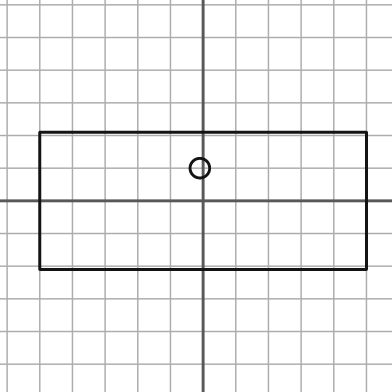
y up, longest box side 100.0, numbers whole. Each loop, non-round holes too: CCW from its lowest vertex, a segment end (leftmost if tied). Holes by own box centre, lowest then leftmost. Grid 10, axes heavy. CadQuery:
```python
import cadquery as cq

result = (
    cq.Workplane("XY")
    .moveTo(-50.0, -21.0)
    .lineTo(50.0, -21.0)
    .lineTo(50.0, 21.0)
    .lineTo(-50.0, 21.0)
    .close()
    .moveTo(-1.0, 10.0)
    .circle(3.0)
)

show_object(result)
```